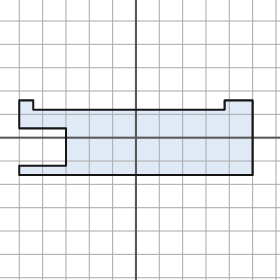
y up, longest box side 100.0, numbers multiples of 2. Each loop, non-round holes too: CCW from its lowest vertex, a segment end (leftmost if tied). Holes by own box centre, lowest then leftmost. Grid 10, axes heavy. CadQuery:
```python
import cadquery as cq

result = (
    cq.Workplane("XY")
    .moveTo(-50.0, -16.0)
    .lineTo(50.0, -16.0)
    .lineTo(50.0, 16.0)
    .lineTo(38.0, 16.0)
    .lineTo(38.0, 12.0)
    .lineTo(-44.0, 12.0)
    .lineTo(-44.0, 16.0)
    .lineTo(-50.0, 16.0)
    .lineTo(-50.0, 4.0)
    .lineTo(-30.0, 4.0)
    .lineTo(-30.0, -12.0)
    .lineTo(-50.0, -12.0)
    .close()
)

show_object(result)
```